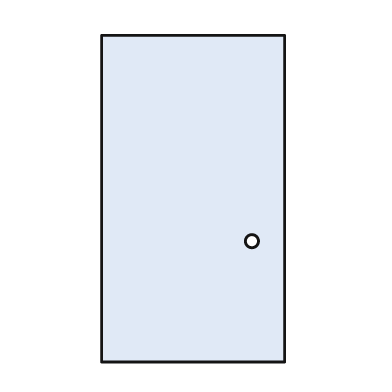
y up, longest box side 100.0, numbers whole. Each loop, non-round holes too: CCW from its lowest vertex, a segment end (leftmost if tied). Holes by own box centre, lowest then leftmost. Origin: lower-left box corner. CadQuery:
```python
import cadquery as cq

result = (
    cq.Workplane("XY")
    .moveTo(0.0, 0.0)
    .lineTo(56.0, 0.0)
    .lineTo(56.0, 100.0)
    .lineTo(0.0, 100.0)
    .close()
    .moveTo(46.0, 37.0)
    .circle(2.0)
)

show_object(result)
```